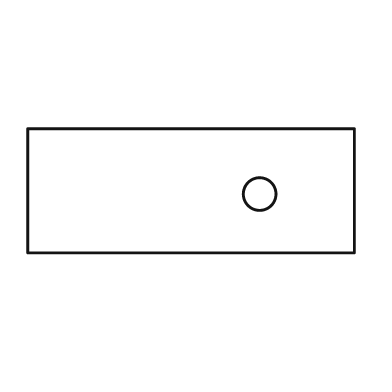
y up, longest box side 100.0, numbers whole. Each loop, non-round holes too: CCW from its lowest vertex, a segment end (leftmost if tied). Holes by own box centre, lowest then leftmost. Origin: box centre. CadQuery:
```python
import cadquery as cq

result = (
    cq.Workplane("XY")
    .moveTo(-50.0, -19.0)
    .lineTo(50.0, -19.0)
    .lineTo(50.0, 19.0)
    .lineTo(-50.0, 19.0)
    .close()
    .moveTo(21.0, -1.0)
    .circle(5.0)
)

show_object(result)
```